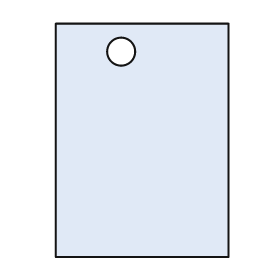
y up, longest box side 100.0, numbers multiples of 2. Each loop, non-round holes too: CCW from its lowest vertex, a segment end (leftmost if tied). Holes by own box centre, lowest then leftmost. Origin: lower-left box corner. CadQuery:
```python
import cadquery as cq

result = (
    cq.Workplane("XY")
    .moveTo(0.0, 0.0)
    .lineTo(74.0, 0.0)
    .lineTo(74.0, 100.0)
    .lineTo(0.0, 100.0)
    .close()
    .moveTo(28.0, 88.0)
    .circle(6.0)
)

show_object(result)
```